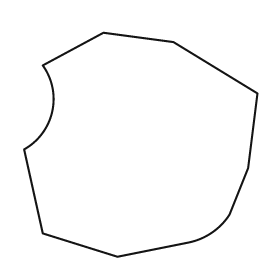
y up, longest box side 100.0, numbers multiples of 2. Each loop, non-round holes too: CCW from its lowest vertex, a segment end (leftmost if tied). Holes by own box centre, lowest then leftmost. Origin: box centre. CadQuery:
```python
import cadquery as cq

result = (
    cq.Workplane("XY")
    .moveTo(-10.0, -48.0)
    .lineTo(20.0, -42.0)
    .threePointArc((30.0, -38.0), (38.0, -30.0))
    .lineTo(46.0, -10.0)
    .lineTo(50.0, 22.0)
    .lineTo(14.0, 44.0)
    .lineTo(-16.0, 48.0)
    .lineTo(-42.0, 34.0)
    .threePointArc((-38.0, 14.0), (-50.0, -2.0))
    .lineTo(-42.0, -38.0)
    .close()
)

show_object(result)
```